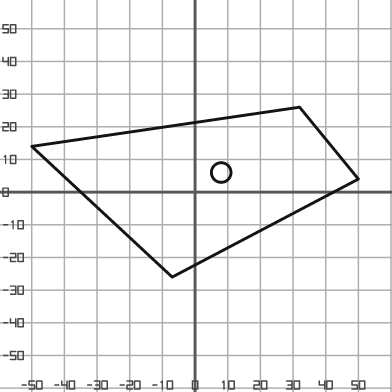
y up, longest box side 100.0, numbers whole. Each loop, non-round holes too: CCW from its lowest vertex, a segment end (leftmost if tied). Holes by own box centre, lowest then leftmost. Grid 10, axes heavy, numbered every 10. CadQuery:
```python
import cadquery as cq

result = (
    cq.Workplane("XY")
    .moveTo(-7.0, -26.0)
    .lineTo(50.0, 4.0)
    .lineTo(32.0, 26.0)
    .lineTo(-50.0, 14.0)
    .close()
    .moveTo(8.0, 6.0)
    .circle(3.0)
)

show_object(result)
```